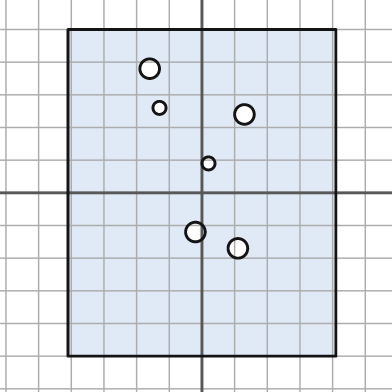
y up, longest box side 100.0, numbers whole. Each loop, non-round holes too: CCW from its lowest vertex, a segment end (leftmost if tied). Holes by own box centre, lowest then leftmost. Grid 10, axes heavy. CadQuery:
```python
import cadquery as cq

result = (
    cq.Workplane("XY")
    .moveTo(-41.0, -50.0)
    .lineTo(41.0, -50.0)
    .lineTo(41.0, 50.0)
    .lineTo(-41.0, 50.0)
    .close()
    .moveTo(11.0, -17.0)
    .circle(3.0)
    .moveTo(-2.0, -12.0)
    .circle(3.0)
    .moveTo(2.0, 9.0)
    .circle(2.0)
    .moveTo(13.0, 24.0)
    .circle(3.0)
    .moveTo(-13.0, 26.0)
    .circle(2.0)
    .moveTo(-16.0, 38.0)
    .circle(3.0)
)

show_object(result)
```